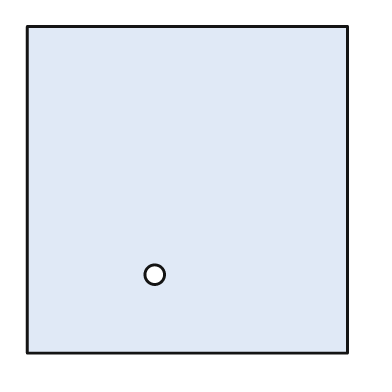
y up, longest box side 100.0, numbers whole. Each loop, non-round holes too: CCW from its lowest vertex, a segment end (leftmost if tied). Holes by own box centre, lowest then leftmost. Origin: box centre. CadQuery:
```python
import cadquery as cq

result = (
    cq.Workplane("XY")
    .moveTo(-49.0, -50.0)
    .lineTo(49.0, -50.0)
    .lineTo(49.0, 50.0)
    .lineTo(-49.0, 50.0)
    .close()
    .moveTo(-10.0, -26.0)
    .circle(3.0)
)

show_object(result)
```